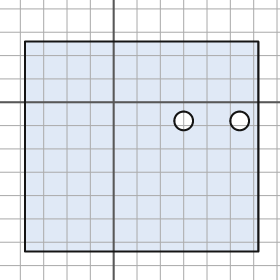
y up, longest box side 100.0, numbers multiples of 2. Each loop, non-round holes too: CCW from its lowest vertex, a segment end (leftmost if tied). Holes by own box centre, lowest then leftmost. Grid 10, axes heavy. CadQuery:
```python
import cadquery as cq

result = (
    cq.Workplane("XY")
    .moveTo(-38.0, -64.0)
    .lineTo(62.0, -64.0)
    .lineTo(62.0, 26.0)
    .lineTo(-38.0, 26.0)
    .close()
    .moveTo(30.0, -8.0)
    .circle(4.0)
    .moveTo(54.0, -8.0)
    .circle(4.0)
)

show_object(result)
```